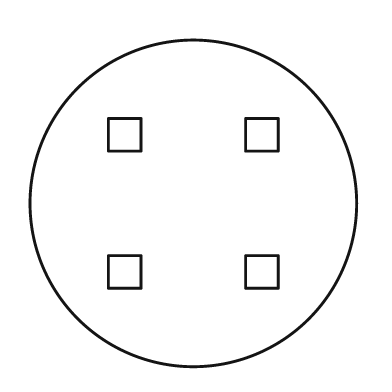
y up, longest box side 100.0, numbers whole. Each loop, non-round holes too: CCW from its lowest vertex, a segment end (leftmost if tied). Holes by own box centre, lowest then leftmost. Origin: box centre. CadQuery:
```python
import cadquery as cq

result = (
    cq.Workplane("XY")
    .moveTo(0.0, 0.0)
    .circle(50.0)
    .moveTo(-26.0, -26.0)
    .lineTo(-16.0, -26.0)
    .lineTo(-16.0, -16.0)
    .lineTo(-26.0, -16.0)
    .close()
    .moveTo(16.0, -26.0)
    .lineTo(26.0, -26.0)
    .lineTo(26.0, -16.0)
    .lineTo(16.0, -16.0)
    .close()
    .moveTo(-26.0, 16.0)
    .lineTo(-16.0, 16.0)
    .lineTo(-16.0, 26.0)
    .lineTo(-26.0, 26.0)
    .close()
    .moveTo(16.0, 16.0)
    .lineTo(26.0, 16.0)
    .lineTo(26.0, 26.0)
    .lineTo(16.0, 26.0)
    .close()
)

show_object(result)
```